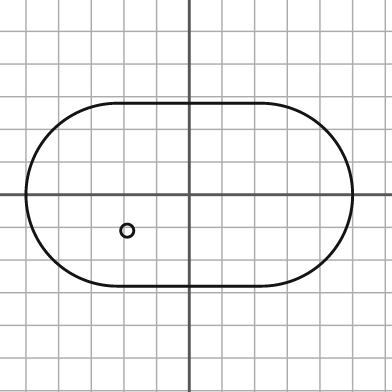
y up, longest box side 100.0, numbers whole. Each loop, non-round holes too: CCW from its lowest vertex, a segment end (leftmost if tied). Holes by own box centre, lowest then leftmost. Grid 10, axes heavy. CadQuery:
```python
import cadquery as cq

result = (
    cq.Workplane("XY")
    .moveTo(-22.0, -28.0)
    .lineTo(22.0, -28.0)
    .threePointArc((50.0, 0.0), (22.0, 28.0))
    .lineTo(-22.0, 28.0)
    .threePointArc((-50.0, 0.0), (-22.0, -28.0))
    .close()
    .moveTo(-19.0, -11.0)
    .circle(2.0)
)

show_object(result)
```